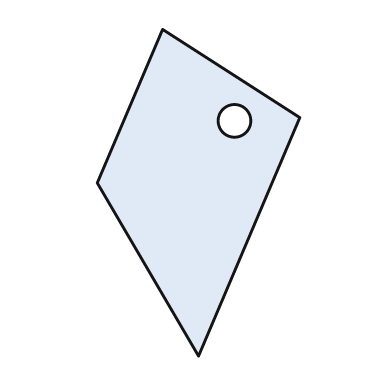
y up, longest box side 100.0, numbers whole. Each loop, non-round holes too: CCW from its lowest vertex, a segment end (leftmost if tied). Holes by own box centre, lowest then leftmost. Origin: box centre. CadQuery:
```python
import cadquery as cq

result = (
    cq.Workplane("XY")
    .moveTo(0.0, -50.0)
    .lineTo(31.0, 23.0)
    .lineTo(-11.0, 50.0)
    .lineTo(-31.0, 3.0)
    .close()
    .moveTo(11.0, 22.0)
    .circle(5.0)
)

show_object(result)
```